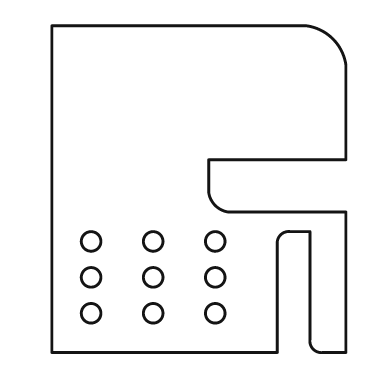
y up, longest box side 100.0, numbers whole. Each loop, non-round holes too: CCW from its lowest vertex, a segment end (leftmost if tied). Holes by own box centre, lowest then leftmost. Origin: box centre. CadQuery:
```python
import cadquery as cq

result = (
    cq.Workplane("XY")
    .moveTo(-45.0, -50.0)
    .lineTo(24.0, -50.0)
    .lineTo(24.0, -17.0)
    .threePointArc((25.0, -14.0), (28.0, -13.0))
    .lineTo(34.0, -13.0)
    .lineTo(34.0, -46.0)
    .threePointArc((35.0, -49.0), (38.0, -50.0))
    .lineTo(45.0, -50.0)
    .lineTo(45.0, -7.0)
    .lineTo(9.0, -7.0)
    .threePointArc((5.0, -5.0), (3.0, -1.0))
    .lineTo(3.0, 9.0)
    .lineTo(45.0, 9.0)
    .lineTo(45.0, 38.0)
    .threePointArc((41.0, 46.0), (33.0, 50.0))
    .lineTo(-45.0, 50.0)
    .close()
    .moveTo(-33.0, -38.0)
    .circle(3.0)
    .moveTo(-14.0, -38.0)
    .circle(3.0)
    .moveTo(5.0, -38.0)
    .circle(3.0)
    .moveTo(-33.0, -27.0)
    .circle(3.0)
    .moveTo(-14.0, -27.0)
    .circle(3.0)
    .moveTo(5.0, -27.0)
    .circle(3.0)
    .moveTo(-33.0, -16.0)
    .circle(3.0)
    .moveTo(-14.0, -16.0)
    .circle(3.0)
    .moveTo(5.0, -16.0)
    .circle(3.0)
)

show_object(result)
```